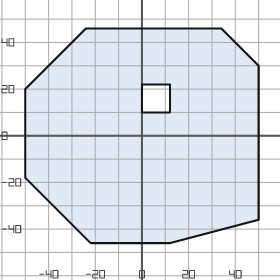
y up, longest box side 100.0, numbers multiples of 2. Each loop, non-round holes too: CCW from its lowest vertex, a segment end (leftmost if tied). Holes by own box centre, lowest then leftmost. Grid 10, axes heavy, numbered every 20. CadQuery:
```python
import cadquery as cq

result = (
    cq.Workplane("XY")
    .moveTo(-22.0, -46.0)
    .lineTo(12.0, -46.0)
    .lineTo(50.0, -36.0)
    .lineTo(50.0, 30.0)
    .lineTo(34.0, 46.0)
    .lineTo(-24.0, 46.0)
    .lineTo(-50.0, 20.0)
    .lineTo(-50.0, -18.0)
    .close()
    .moveTo(0.0, 10.0)
    .lineTo(12.0, 10.0)
    .lineTo(12.0, 22.0)
    .lineTo(0.0, 22.0)
    .close()
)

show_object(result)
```